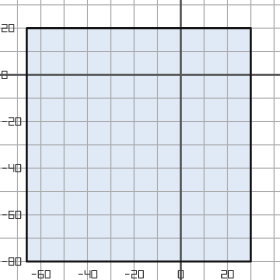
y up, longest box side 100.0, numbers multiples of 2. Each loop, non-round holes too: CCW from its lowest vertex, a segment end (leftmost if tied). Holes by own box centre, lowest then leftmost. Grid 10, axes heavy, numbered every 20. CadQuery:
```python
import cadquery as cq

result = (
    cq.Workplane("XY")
    .moveTo(-66.0, -80.0)
    .lineTo(30.0, -80.0)
    .lineTo(30.0, 20.0)
    .lineTo(-66.0, 20.0)
    .close()
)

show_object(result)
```